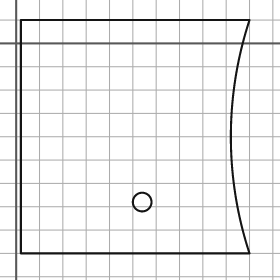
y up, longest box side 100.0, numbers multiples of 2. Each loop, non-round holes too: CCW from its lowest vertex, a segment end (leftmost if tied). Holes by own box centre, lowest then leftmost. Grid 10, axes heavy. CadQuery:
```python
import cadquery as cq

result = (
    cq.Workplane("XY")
    .moveTo(2.0, -90.0)
    .lineTo(100.0, -90.0)
    .threePointArc((92.0, -40.0), (100.0, 10.0))
    .lineTo(2.0, 10.0)
    .close()
    .moveTo(54.0, -68.0)
    .circle(4.0)
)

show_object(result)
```